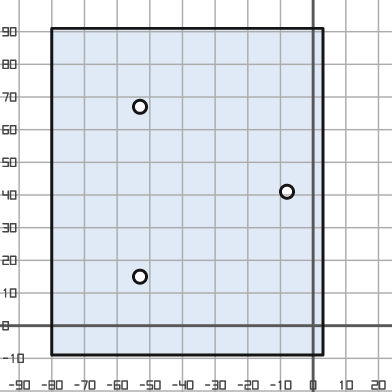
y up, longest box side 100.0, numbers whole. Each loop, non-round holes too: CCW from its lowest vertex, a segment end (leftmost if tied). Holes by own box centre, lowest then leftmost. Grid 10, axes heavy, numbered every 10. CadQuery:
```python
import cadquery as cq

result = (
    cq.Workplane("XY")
    .moveTo(-80.0, -9.0)
    .lineTo(3.0, -9.0)
    .lineTo(3.0, 91.0)
    .lineTo(-80.0, 91.0)
    .close()
    .moveTo(-53.0, 15.0)
    .circle(2.0)
    .moveTo(-8.0, 41.0)
    .circle(2.0)
    .moveTo(-53.0, 67.0)
    .circle(2.0)
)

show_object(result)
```